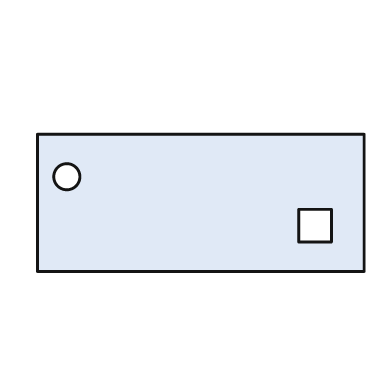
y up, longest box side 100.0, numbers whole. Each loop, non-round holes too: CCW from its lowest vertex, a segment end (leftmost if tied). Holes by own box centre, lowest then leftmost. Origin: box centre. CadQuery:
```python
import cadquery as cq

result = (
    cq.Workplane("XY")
    .moveTo(-50.0, -21.0)
    .lineTo(50.0, -21.0)
    .lineTo(50.0, 21.0)
    .lineTo(-50.0, 21.0)
    .close()
    .moveTo(30.0, -12.0)
    .lineTo(40.0, -12.0)
    .lineTo(40.0, -2.0)
    .lineTo(30.0, -2.0)
    .close()
    .moveTo(-41.0, 8.0)
    .circle(4.0)
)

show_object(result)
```